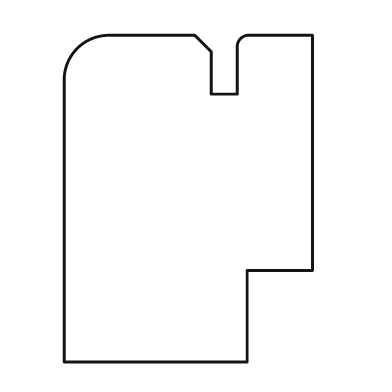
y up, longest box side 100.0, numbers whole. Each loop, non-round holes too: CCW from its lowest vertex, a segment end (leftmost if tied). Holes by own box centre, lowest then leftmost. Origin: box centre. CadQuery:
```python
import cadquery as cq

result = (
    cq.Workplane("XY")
    .moveTo(-38.0, -50.0)
    .lineTo(18.0, -50.0)
    .lineTo(18.0, -22.0)
    .lineTo(38.0, -22.0)
    .lineTo(38.0, 50.0)
    .lineTo(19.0, 50.0)
    .threePointArc((16.0, 49.0), (15.0, 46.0))
    .lineTo(15.0, 32.0)
    .lineTo(7.0, 32.0)
    .lineTo(7.0, 45.0)
    .lineTo(2.0, 50.0)
    .lineTo(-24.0, 50.0)
    .threePointArc((-34.0, 46.0), (-38.0, 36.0))
    .close()
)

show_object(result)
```